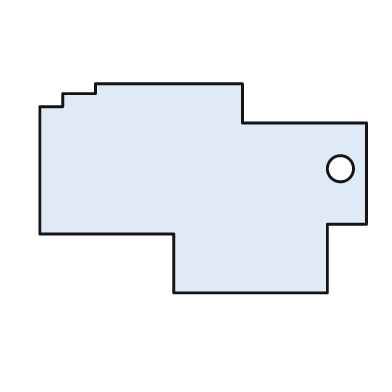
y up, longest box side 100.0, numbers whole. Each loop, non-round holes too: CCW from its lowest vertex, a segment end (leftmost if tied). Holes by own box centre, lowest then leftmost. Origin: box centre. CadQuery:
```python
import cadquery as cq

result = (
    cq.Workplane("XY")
    .moveTo(-9.0, -32.0)
    .lineTo(38.0, -32.0)
    .lineTo(38.0, -11.0)
    .lineTo(50.0, -11.0)
    .lineTo(50.0, 20.0)
    .lineTo(12.0, 20.0)
    .lineTo(12.0, 32.0)
    .lineTo(-33.0, 32.0)
    .lineTo(-33.0, 29.0)
    .lineTo(-43.0, 29.0)
    .lineTo(-43.0, 25.0)
    .lineTo(-50.0, 25.0)
    .lineTo(-50.0, -14.0)
    .lineTo(-9.0, -14.0)
    .close()
    .moveTo(42.0, 6.0)
    .circle(4.0)
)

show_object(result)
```